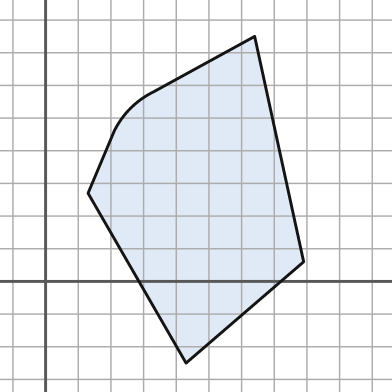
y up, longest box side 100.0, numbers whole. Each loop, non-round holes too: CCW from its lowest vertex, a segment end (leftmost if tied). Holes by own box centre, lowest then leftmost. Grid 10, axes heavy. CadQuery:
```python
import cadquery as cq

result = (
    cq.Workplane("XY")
    .moveTo(43.0, -25.0)
    .lineTo(79.0, 6.0)
    .lineTo(64.0, 75.0)
    .lineTo(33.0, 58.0)
    .threePointArc((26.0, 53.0), (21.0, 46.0))
    .lineTo(13.0, 27.0)
    .close()
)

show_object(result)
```